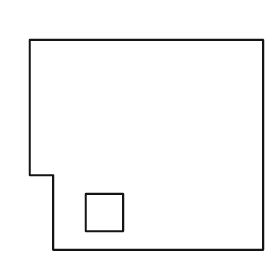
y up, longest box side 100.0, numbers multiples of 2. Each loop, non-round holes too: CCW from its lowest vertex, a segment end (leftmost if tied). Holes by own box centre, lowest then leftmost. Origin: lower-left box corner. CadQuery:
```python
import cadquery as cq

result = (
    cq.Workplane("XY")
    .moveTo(10.0, 0.0)
    .lineTo(100.0, 0.0)
    .lineTo(100.0, 90.0)
    .lineTo(0.0, 90.0)
    .lineTo(0.0, 32.0)
    .lineTo(10.0, 32.0)
    .close()
    .moveTo(24.0, 8.0)
    .lineTo(40.0, 8.0)
    .lineTo(40.0, 24.0)
    .lineTo(24.0, 24.0)
    .close()
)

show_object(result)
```